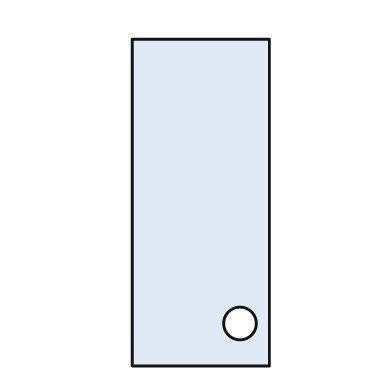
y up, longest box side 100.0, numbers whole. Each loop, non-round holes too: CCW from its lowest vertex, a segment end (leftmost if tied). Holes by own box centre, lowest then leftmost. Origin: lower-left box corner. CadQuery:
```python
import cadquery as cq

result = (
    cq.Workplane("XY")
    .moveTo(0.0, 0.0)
    .lineTo(42.0, 0.0)
    .lineTo(42.0, 100.0)
    .lineTo(0.0, 100.0)
    .close()
    .moveTo(33.0, 13.0)
    .circle(5.0)
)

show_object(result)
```